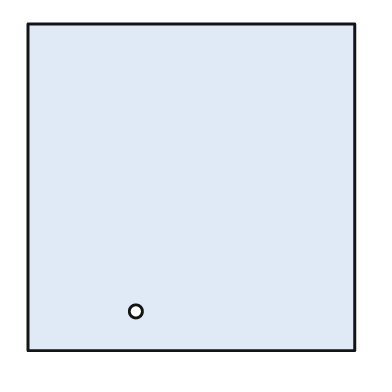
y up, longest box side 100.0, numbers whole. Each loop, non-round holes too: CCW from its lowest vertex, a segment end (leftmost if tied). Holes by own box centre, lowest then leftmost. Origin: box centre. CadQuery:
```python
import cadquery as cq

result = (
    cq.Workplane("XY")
    .moveTo(-50.0, -50.0)
    .lineTo(50.0, -50.0)
    .lineTo(50.0, 50.0)
    .lineTo(-50.0, 50.0)
    .close()
    .moveTo(-17.0, -38.0)
    .circle(2.0)
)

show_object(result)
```